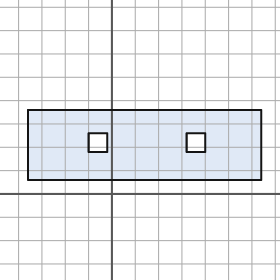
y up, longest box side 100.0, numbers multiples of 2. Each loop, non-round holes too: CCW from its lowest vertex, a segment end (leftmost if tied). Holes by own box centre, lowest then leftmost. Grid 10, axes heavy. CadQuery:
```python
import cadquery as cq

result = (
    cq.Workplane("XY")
    .moveTo(-36.0, 6.0)
    .lineTo(64.0, 6.0)
    .lineTo(64.0, 36.0)
    .lineTo(-36.0, 36.0)
    .close()
    .moveTo(-10.0, 18.0)
    .lineTo(-2.0, 18.0)
    .lineTo(-2.0, 26.0)
    .lineTo(-10.0, 26.0)
    .close()
    .moveTo(32.0, 18.0)
    .lineTo(40.0, 18.0)
    .lineTo(40.0, 26.0)
    .lineTo(32.0, 26.0)
    .close()
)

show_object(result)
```